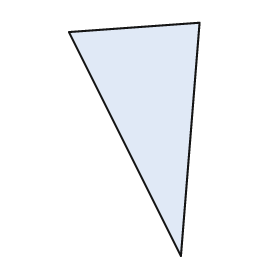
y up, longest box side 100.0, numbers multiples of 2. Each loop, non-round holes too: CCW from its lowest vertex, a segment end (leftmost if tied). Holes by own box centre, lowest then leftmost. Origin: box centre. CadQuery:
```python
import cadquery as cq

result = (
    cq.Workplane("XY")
    .moveTo(20.0, -50.0)
    .lineTo(28.0, 50.0)
    .lineTo(-28.0, 46.0)
    .close()
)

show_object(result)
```